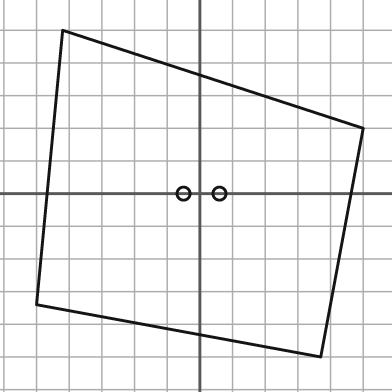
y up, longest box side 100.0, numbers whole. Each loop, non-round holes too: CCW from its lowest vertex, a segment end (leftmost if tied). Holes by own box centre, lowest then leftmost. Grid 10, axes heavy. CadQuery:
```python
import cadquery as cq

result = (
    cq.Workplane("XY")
    .moveTo(37.0, -50.0)
    .lineTo(50.0, 20.0)
    .lineTo(-42.0, 50.0)
    .lineTo(-50.0, -34.0)
    .close()
    .moveTo(-5.0, 0.0)
    .circle(2.0)
    .moveTo(6.0, 0.0)
    .circle(2.0)
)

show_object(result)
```